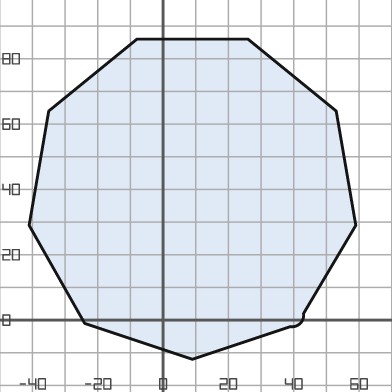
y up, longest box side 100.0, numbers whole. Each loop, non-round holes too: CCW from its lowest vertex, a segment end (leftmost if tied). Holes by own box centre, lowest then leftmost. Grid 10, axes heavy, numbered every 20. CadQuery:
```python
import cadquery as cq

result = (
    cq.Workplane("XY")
    .moveTo(9.0, -12.0)
    .lineTo(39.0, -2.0)
    .threePointArc((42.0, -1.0), (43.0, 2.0))
    .lineTo(59.0, 29.0)
    .lineTo(53.0, 64.0)
    .lineTo(26.0, 86.0)
    .lineTo(-8.0, 86.0)
    .lineTo(-35.0, 64.0)
    .lineTo(-41.0, 29.0)
    .lineTo(-24.0, -1.0)
    .close()
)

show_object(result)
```